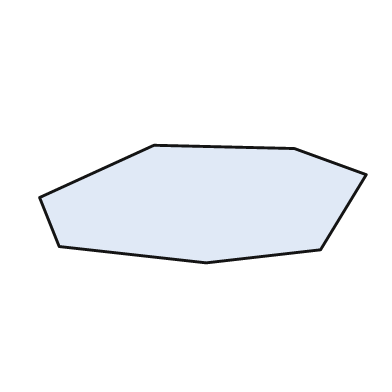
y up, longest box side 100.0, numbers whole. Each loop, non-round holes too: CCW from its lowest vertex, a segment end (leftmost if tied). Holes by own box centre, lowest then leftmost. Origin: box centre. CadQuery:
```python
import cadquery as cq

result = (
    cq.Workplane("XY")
    .moveTo(1.0, -18.0)
    .lineTo(36.0, -14.0)
    .lineTo(50.0, 9.0)
    .lineTo(28.0, 17.0)
    .lineTo(-15.0, 18.0)
    .lineTo(-50.0, 2.0)
    .lineTo(-44.0, -13.0)
    .close()
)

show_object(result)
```